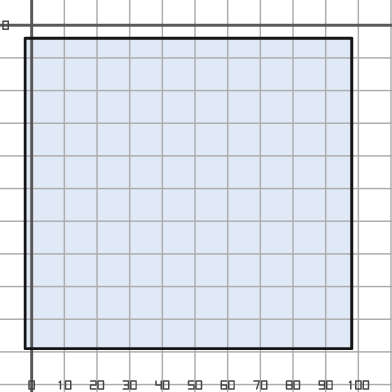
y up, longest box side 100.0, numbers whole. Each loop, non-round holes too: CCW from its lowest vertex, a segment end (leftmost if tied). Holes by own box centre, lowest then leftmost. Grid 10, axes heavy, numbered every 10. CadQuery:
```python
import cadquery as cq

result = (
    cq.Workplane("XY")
    .moveTo(-2.0, -99.0)
    .lineTo(98.0, -99.0)
    .lineTo(98.0, -4.0)
    .lineTo(-2.0, -4.0)
    .close()
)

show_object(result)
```